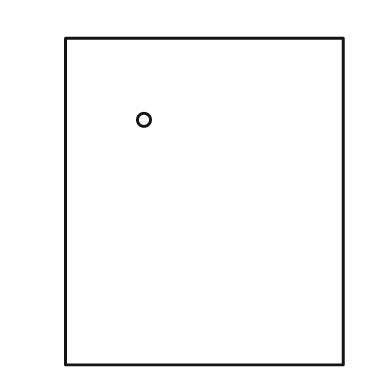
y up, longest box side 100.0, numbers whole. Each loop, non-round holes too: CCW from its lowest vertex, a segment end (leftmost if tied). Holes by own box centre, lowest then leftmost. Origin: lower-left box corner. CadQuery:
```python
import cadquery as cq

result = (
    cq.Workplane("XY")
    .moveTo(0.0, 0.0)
    .lineTo(85.0, 0.0)
    .lineTo(85.0, 100.0)
    .lineTo(0.0, 100.0)
    .close()
    .moveTo(24.0, 75.0)
    .circle(2.0)
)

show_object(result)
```